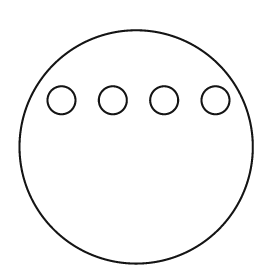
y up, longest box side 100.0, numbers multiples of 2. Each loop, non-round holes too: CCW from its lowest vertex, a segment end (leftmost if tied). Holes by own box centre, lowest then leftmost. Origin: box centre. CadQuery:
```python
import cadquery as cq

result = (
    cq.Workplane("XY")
    .moveTo(0.0, 0.0)
    .circle(50.0)
    .moveTo(-32.0, 20.0)
    .circle(6.0)
    .moveTo(-10.0, 20.0)
    .circle(6.0)
    .moveTo(12.0, 20.0)
    .circle(6.0)
    .moveTo(34.0, 20.0)
    .circle(6.0)
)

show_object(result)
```